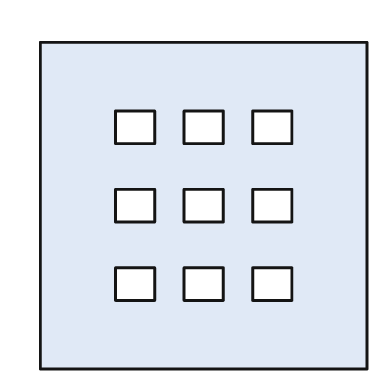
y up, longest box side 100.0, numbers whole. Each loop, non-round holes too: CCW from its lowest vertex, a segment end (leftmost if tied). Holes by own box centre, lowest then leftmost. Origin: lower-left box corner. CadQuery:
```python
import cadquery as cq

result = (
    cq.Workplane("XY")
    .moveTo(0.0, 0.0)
    .lineTo(100.0, 0.0)
    .lineTo(100.0, 100.0)
    .lineTo(0.0, 100.0)
    .close()
    .moveTo(23.0, 21.0)
    .lineTo(35.0, 21.0)
    .lineTo(35.0, 31.0)
    .lineTo(23.0, 31.0)
    .close()
    .moveTo(44.0, 21.0)
    .lineTo(56.0, 21.0)
    .lineTo(56.0, 31.0)
    .lineTo(44.0, 31.0)
    .close()
    .moveTo(65.0, 21.0)
    .lineTo(77.0, 21.0)
    .lineTo(77.0, 31.0)
    .lineTo(65.0, 31.0)
    .close()
    .moveTo(23.0, 45.0)
    .lineTo(35.0, 45.0)
    .lineTo(35.0, 55.0)
    .lineTo(23.0, 55.0)
    .close()
    .moveTo(44.0, 45.0)
    .lineTo(56.0, 45.0)
    .lineTo(56.0, 55.0)
    .lineTo(44.0, 55.0)
    .close()
    .moveTo(65.0, 45.0)
    .lineTo(77.0, 45.0)
    .lineTo(77.0, 55.0)
    .lineTo(65.0, 55.0)
    .close()
    .moveTo(23.0, 69.0)
    .lineTo(35.0, 69.0)
    .lineTo(35.0, 79.0)
    .lineTo(23.0, 79.0)
    .close()
    .moveTo(44.0, 69.0)
    .lineTo(56.0, 69.0)
    .lineTo(56.0, 79.0)
    .lineTo(44.0, 79.0)
    .close()
    .moveTo(65.0, 69.0)
    .lineTo(77.0, 69.0)
    .lineTo(77.0, 79.0)
    .lineTo(65.0, 79.0)
    .close()
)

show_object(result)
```